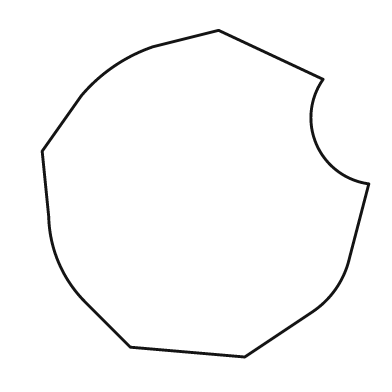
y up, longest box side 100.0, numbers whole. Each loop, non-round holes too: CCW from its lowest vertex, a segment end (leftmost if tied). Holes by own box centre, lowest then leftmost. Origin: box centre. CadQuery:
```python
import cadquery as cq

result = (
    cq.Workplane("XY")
    .moveTo(12.0, -50.0)
    .lineTo(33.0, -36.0)
    .threePointArc((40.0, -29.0), (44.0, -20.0))
    .lineTo(50.0, 3.0)
    .threePointArc((34.0, 15.0), (36.0, 35.0))
    .lineTo(4.0, 50.0)
    .lineTo(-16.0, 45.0)
    .threePointArc((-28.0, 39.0), (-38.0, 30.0))
    .lineTo(-50.0, 13.0)
    .lineTo(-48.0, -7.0)
    .threePointArc((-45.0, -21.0), (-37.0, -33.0))
    .lineTo(-23.0, -47.0)
    .close()
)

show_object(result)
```